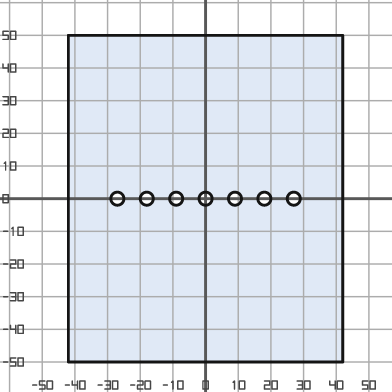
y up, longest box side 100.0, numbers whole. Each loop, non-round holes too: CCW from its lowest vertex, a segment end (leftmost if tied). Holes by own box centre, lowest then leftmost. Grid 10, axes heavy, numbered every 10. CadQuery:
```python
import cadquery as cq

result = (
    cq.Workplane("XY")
    .moveTo(-42.0, -50.0)
    .lineTo(42.0, -50.0)
    .lineTo(42.0, 50.0)
    .lineTo(-42.0, 50.0)
    .close()
    .moveTo(-27.0, 0.0)
    .circle(2.0)
    .moveTo(-18.0, 0.0)
    .circle(2.0)
    .moveTo(-9.0, 0.0)
    .circle(2.0)
    .moveTo(0.0, 0.0)
    .circle(2.0)
    .moveTo(9.0, 0.0)
    .circle(2.0)
    .moveTo(18.0, 0.0)
    .circle(2.0)
    .moveTo(27.0, 0.0)
    .circle(2.0)
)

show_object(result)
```